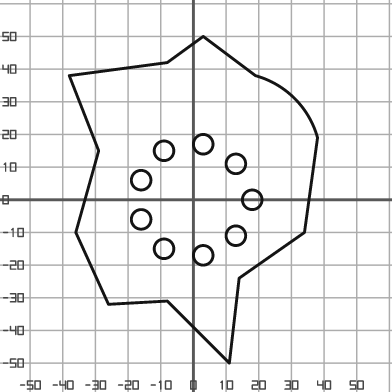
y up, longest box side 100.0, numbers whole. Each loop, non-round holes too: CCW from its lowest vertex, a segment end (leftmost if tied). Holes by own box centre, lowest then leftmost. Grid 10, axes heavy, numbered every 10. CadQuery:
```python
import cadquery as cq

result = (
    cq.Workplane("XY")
    .moveTo(11.0, -50.0)
    .lineTo(14.0, -24.0)
    .lineTo(34.0, -10.0)
    .lineTo(38.0, 19.0)
    .threePointArc((31.0, 31.0), (19.0, 38.0))
    .lineTo(3.0, 50.0)
    .lineTo(-8.0, 42.0)
    .lineTo(-38.0, 38.0)
    .lineTo(-29.0, 15.0)
    .lineTo(-36.0, -10.0)
    .lineTo(-26.0, -32.0)
    .lineTo(-8.0, -31.0)
    .close()
    .moveTo(3.0, -17.0)
    .circle(3.0)
    .moveTo(-9.0, -15.0)
    .circle(3.0)
    .moveTo(13.0, -11.0)
    .circle(3.0)
    .moveTo(-16.0, -6.0)
    .circle(3.0)
    .moveTo(18.0, 0.0)
    .circle(3.0)
    .moveTo(-16.0, 6.0)
    .circle(3.0)
    .moveTo(13.0, 11.0)
    .circle(3.0)
    .moveTo(-9.0, 15.0)
    .circle(3.0)
    .moveTo(3.0, 17.0)
    .circle(3.0)
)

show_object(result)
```